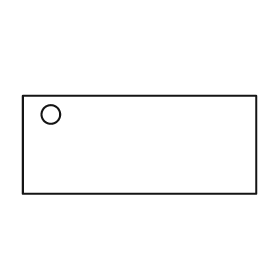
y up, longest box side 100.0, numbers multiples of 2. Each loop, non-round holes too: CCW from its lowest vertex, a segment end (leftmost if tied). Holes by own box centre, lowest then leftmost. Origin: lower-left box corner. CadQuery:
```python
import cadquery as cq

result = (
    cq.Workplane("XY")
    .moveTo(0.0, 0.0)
    .lineTo(100.0, 0.0)
    .lineTo(100.0, 42.0)
    .lineTo(0.0, 42.0)
    .close()
    .moveTo(12.0, 34.0)
    .circle(4.0)
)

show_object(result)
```